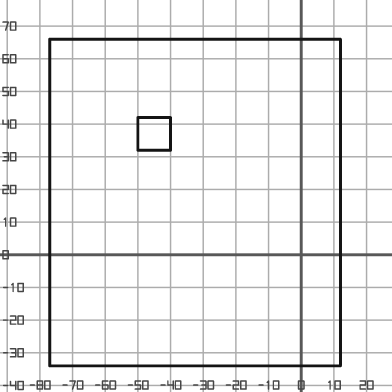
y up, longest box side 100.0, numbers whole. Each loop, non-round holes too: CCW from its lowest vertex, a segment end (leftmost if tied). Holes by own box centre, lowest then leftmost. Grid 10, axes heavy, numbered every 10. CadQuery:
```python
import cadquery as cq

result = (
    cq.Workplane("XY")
    .moveTo(-77.0, -34.0)
    .lineTo(12.0, -34.0)
    .lineTo(12.0, 66.0)
    .lineTo(-77.0, 66.0)
    .close()
    .moveTo(-50.0, 32.0)
    .lineTo(-40.0, 32.0)
    .lineTo(-40.0, 42.0)
    .lineTo(-50.0, 42.0)
    .close()
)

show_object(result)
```